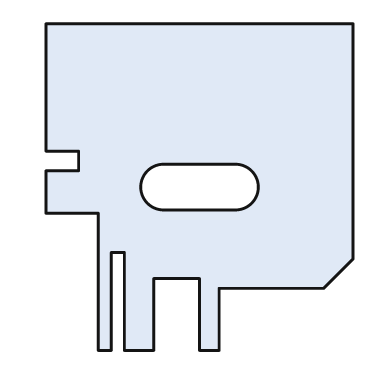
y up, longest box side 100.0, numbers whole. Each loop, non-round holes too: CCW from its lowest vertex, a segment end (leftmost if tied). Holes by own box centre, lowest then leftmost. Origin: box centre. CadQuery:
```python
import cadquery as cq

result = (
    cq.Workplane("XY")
    .moveTo(-31.0, -50.0)
    .lineTo(-27.0, -50.0)
    .lineTo(-27.0, -20.0)
    .lineTo(-23.0, -20.0)
    .lineTo(-23.0, -50.0)
    .lineTo(-14.0, -50.0)
    .lineTo(-14.0, -28.0)
    .lineTo(0.0, -28.0)
    .lineTo(0.0, -50.0)
    .lineTo(6.0, -50.0)
    .lineTo(6.0, -31.0)
    .lineTo(38.0, -31.0)
    .lineTo(47.0, -22.0)
    .lineTo(47.0, 50.0)
    .lineTo(-47.0, 50.0)
    .lineTo(-47.0, 11.0)
    .lineTo(-37.0, 11.0)
    .lineTo(-37.0, 5.0)
    .lineTo(-47.0, 5.0)
    .lineTo(-47.0, -8.0)
    .lineTo(-31.0, -8.0)
    .close()
    .moveTo(-11.0, -7.0)
    .lineTo(11.0, -7.0)
    .threePointArc((18.0, 0.0), (11.0, 7.0))
    .lineTo(-11.0, 7.0)
    .threePointArc((-18.0, 0.0), (-11.0, -7.0))
    .close()
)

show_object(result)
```